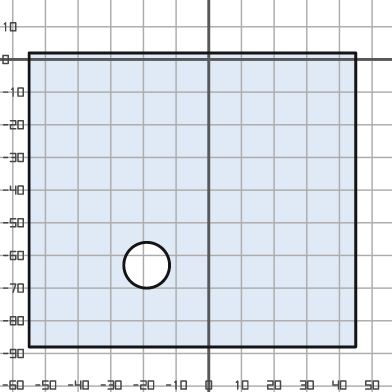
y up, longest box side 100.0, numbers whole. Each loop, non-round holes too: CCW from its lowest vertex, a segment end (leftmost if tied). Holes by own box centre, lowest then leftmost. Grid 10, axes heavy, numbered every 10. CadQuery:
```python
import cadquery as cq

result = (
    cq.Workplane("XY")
    .moveTo(-55.0, -88.0)
    .lineTo(45.0, -88.0)
    .lineTo(45.0, 2.0)
    .lineTo(-55.0, 2.0)
    .close()
    .moveTo(-19.0, -63.0)
    .circle(7.0)
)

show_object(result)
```